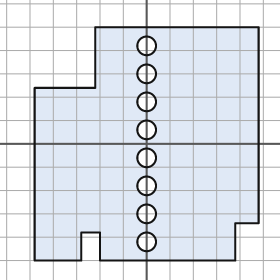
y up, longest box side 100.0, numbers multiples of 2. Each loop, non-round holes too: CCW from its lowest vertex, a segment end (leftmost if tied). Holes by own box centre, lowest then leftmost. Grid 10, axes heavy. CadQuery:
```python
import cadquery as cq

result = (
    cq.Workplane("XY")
    .moveTo(-48.0, -50.0)
    .lineTo(-28.0, -50.0)
    .lineTo(-28.0, -38.0)
    .lineTo(-20.0, -38.0)
    .lineTo(-20.0, -50.0)
    .lineTo(38.0, -50.0)
    .lineTo(38.0, -34.0)
    .lineTo(48.0, -34.0)
    .lineTo(48.0, 50.0)
    .lineTo(-22.0, 50.0)
    .lineTo(-22.0, 24.0)
    .lineTo(-48.0, 24.0)
    .close()
    .moveTo(0.0, -42.0)
    .circle(4.0)
    .moveTo(0.0, -30.0)
    .circle(4.0)
    .moveTo(0.0, -18.0)
    .circle(4.0)
    .moveTo(0.0, -6.0)
    .circle(4.0)
    .moveTo(0.0, 6.0)
    .circle(4.0)
    .moveTo(0.0, 18.0)
    .circle(4.0)
    .moveTo(0.0, 30.0)
    .circle(4.0)
    .moveTo(0.0, 42.0)
    .circle(4.0)
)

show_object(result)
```